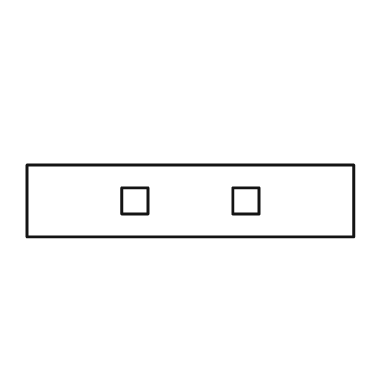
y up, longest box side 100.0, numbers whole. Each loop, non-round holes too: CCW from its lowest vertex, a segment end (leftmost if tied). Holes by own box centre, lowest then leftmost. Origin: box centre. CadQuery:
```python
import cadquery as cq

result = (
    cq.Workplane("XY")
    .moveTo(-50.0, -11.0)
    .lineTo(50.0, -11.0)
    .lineTo(50.0, 11.0)
    .lineTo(-50.0, 11.0)
    .close()
    .moveTo(-21.0, -4.0)
    .lineTo(-13.0, -4.0)
    .lineTo(-13.0, 4.0)
    .lineTo(-21.0, 4.0)
    .close()
    .moveTo(13.0, -4.0)
    .lineTo(21.0, -4.0)
    .lineTo(21.0, 4.0)
    .lineTo(13.0, 4.0)
    .close()
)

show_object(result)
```